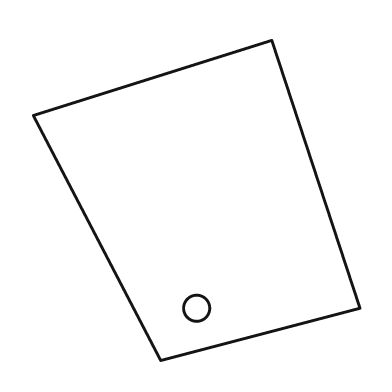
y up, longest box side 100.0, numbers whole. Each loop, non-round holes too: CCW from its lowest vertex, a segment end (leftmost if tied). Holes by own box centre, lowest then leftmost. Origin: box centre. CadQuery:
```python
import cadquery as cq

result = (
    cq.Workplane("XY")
    .moveTo(-11.0, -49.0)
    .lineTo(50.0, -33.0)
    .lineTo(23.0, 49.0)
    .lineTo(-50.0, 26.0)
    .close()
    .moveTo(0.0, -33.0)
    .circle(4.0)
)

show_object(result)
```